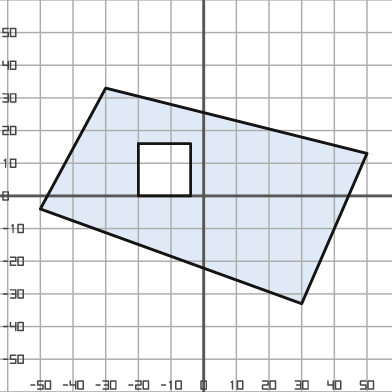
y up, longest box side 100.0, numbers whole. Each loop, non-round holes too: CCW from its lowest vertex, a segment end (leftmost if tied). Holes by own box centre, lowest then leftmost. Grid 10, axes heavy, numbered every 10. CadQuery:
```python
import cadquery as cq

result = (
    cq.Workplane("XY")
    .moveTo(30.0, -33.0)
    .lineTo(50.0, 13.0)
    .lineTo(-30.0, 33.0)
    .lineTo(-50.0, -4.0)
    .close()
    .moveTo(-20.0, 0.0)
    .lineTo(-4.0, 0.0)
    .lineTo(-4.0, 16.0)
    .lineTo(-20.0, 16.0)
    .close()
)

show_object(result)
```